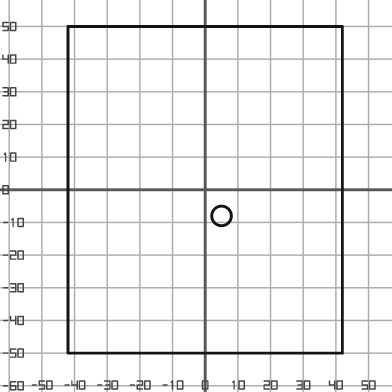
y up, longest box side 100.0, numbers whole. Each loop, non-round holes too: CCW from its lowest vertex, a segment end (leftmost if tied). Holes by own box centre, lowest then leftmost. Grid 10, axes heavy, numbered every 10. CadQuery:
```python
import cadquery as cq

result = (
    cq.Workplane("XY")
    .moveTo(-42.0, -50.0)
    .lineTo(42.0, -50.0)
    .lineTo(42.0, 50.0)
    .lineTo(-42.0, 50.0)
    .close()
    .moveTo(5.0, -8.0)
    .circle(3.0)
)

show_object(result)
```